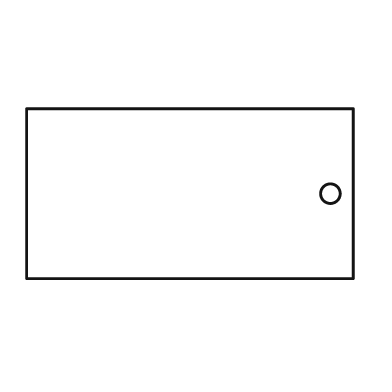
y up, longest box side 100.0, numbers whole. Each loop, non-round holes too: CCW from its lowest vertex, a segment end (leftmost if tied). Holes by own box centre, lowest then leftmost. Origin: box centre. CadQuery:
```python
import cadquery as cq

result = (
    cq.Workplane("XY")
    .moveTo(-50.0, -26.0)
    .lineTo(50.0, -26.0)
    .lineTo(50.0, 26.0)
    .lineTo(-50.0, 26.0)
    .close()
    .moveTo(43.0, 0.0)
    .circle(3.0)
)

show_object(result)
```